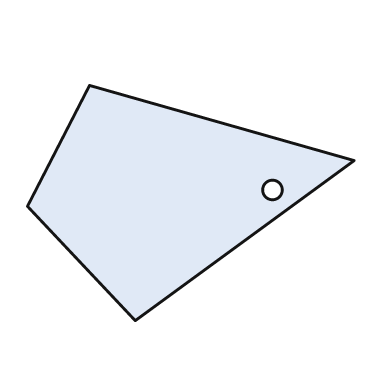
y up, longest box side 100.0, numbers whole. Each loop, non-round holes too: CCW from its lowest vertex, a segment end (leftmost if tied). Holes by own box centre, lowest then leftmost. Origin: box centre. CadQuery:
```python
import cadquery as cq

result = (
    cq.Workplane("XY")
    .moveTo(-17.0, -36.0)
    .lineTo(50.0, 13.0)
    .lineTo(-31.0, 36.0)
    .lineTo(-50.0, -1.0)
    .close()
    .moveTo(25.0, 4.0)
    .circle(3.0)
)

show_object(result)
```